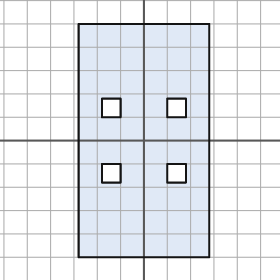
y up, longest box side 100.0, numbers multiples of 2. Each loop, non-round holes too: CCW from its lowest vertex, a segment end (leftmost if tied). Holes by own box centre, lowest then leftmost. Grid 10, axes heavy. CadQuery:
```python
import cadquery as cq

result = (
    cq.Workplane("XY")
    .moveTo(-28.0, -50.0)
    .lineTo(28.0, -50.0)
    .lineTo(28.0, 50.0)
    .lineTo(-28.0, 50.0)
    .close()
    .moveTo(-18.0, -18.0)
    .lineTo(-10.0, -18.0)
    .lineTo(-10.0, -10.0)
    .lineTo(-18.0, -10.0)
    .close()
    .moveTo(10.0, -18.0)
    .lineTo(18.0, -18.0)
    .lineTo(18.0, -10.0)
    .lineTo(10.0, -10.0)
    .close()
    .moveTo(-18.0, 10.0)
    .lineTo(-10.0, 10.0)
    .lineTo(-10.0, 18.0)
    .lineTo(-18.0, 18.0)
    .close()
    .moveTo(10.0, 10.0)
    .lineTo(18.0, 10.0)
    .lineTo(18.0, 18.0)
    .lineTo(10.0, 18.0)
    .close()
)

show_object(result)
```